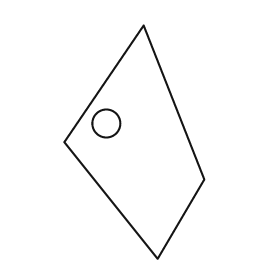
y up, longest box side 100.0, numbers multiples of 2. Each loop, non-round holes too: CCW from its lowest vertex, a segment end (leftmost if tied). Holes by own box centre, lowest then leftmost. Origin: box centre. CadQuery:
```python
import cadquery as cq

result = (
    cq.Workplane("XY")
    .moveTo(10.0, -50.0)
    .lineTo(30.0, -16.0)
    .lineTo(4.0, 50.0)
    .lineTo(-30.0, 0.0)
    .close()
    .moveTo(-12.0, 8.0)
    .circle(6.0)
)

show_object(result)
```